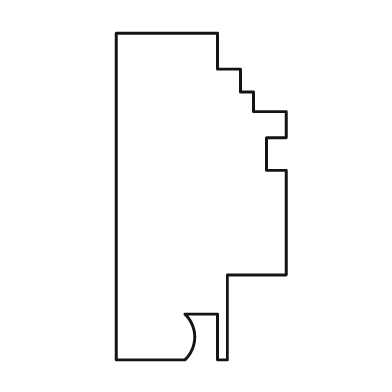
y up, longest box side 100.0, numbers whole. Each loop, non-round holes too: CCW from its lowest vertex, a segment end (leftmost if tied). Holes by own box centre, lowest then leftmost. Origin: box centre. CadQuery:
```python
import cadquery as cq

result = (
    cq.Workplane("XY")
    .moveTo(-26.0, -50.0)
    .lineTo(-5.0, -50.0)
    .threePointArc((-2.0, -43.0), (-5.0, -36.0))
    .lineTo(5.0, -36.0)
    .lineTo(5.0, -50.0)
    .lineTo(8.0, -50.0)
    .lineTo(8.0, -24.0)
    .lineTo(26.0, -24.0)
    .lineTo(26.0, 8.0)
    .lineTo(20.0, 8.0)
    .lineTo(20.0, 18.0)
    .lineTo(26.0, 18.0)
    .lineTo(26.0, 26.0)
    .lineTo(16.0, 26.0)
    .lineTo(16.0, 32.0)
    .lineTo(12.0, 32.0)
    .lineTo(12.0, 39.0)
    .lineTo(5.0, 39.0)
    .lineTo(5.0, 50.0)
    .lineTo(-26.0, 50.0)
    .close()
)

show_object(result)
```